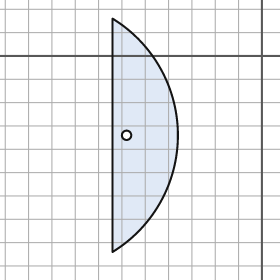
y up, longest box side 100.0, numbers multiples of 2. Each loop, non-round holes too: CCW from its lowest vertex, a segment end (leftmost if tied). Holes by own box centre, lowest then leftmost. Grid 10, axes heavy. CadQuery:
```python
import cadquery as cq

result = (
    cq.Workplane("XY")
    .moveTo(-64.0, -84.0)
    .threePointArc((-36.0, -34.0), (-64.0, 16.0))
    .close()
    .moveTo(-58.0, -34.0)
    .circle(2.0)
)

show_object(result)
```